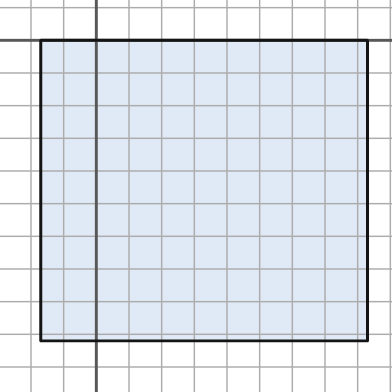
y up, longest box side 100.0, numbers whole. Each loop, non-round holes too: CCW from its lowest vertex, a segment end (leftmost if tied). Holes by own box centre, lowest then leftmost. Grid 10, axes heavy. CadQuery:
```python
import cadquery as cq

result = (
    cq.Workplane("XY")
    .moveTo(-17.0, -92.0)
    .lineTo(83.0, -92.0)
    .lineTo(83.0, 0.0)
    .lineTo(-17.0, 0.0)
    .close()
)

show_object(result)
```